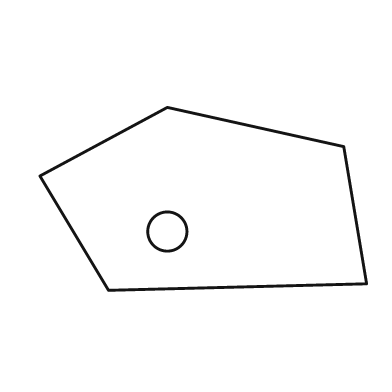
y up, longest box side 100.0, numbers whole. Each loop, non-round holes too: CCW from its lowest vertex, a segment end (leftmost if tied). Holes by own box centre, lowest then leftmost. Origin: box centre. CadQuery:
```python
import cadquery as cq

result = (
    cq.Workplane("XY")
    .moveTo(-29.0, -28.0)
    .lineTo(50.0, -26.0)
    .lineTo(43.0, 16.0)
    .lineTo(-11.0, 28.0)
    .lineTo(-50.0, 7.0)
    .close()
    .moveTo(-11.0, -10.0)
    .circle(6.0)
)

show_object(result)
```